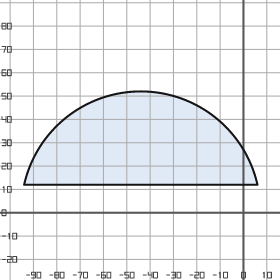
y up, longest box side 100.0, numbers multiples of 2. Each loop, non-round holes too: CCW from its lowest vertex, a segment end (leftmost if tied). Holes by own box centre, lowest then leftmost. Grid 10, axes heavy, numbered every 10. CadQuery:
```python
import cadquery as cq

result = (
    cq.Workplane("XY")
    .moveTo(-94.0, 12.0)
    .lineTo(6.0, 12.0)
    .threePointArc((-44.0, 52.0), (-94.0, 12.0))
    .close()
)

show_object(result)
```